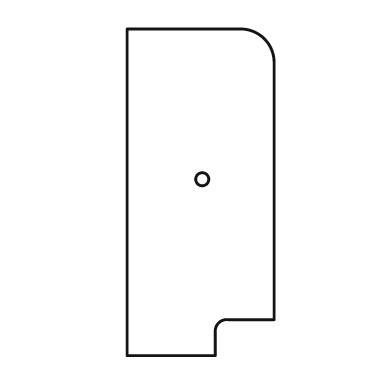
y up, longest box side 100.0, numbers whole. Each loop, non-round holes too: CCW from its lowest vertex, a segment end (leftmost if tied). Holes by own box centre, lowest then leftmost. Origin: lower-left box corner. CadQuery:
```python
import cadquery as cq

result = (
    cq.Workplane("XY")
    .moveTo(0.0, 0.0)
    .lineTo(27.0, 0.0)
    .lineTo(27.0, 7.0)
    .threePointArc((28.0, 10.0), (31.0, 11.0))
    .lineTo(45.0, 11.0)
    .lineTo(45.0, 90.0)
    .threePointArc((42.0, 97.0), (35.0, 100.0))
    .lineTo(0.0, 100.0)
    .close()
    .moveTo(23.0, 54.0)
    .circle(2.0)
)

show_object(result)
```